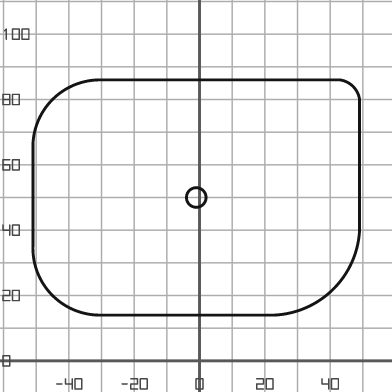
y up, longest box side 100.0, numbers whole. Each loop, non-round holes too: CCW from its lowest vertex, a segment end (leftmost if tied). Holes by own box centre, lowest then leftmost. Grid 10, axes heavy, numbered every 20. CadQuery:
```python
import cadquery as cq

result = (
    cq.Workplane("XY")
    .moveTo(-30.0, 14.0)
    .lineTo(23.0, 14.0)
    .threePointArc((41.0, 22.0), (49.0, 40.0))
    .lineTo(49.0, 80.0)
    .threePointArc((47.0, 84.0), (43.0, 86.0))
    .lineTo(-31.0, 86.0)
    .threePointArc((-45.0, 80.0), (-51.0, 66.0))
    .lineTo(-51.0, 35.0)
    .threePointArc((-45.0, 20.0), (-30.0, 14.0))
    .close()
    .moveTo(-1.0, 50.0)
    .circle(3.0)
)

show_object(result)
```